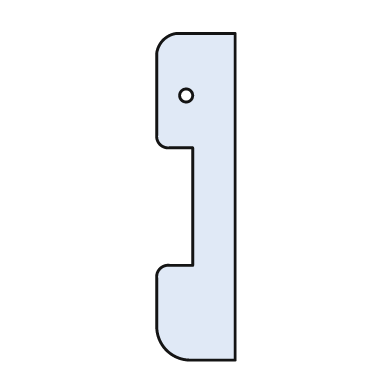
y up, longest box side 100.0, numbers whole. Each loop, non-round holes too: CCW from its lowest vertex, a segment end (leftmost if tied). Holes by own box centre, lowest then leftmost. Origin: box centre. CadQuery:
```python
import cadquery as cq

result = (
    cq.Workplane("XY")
    .moveTo(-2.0, -50.0)
    .lineTo(12.0, -50.0)
    .lineTo(12.0, 50.0)
    .lineTo(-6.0, 50.0)
    .threePointArc((-10.0, 48.0), (-12.0, 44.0))
    .lineTo(-12.0, 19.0)
    .threePointArc((-11.0, 16.0), (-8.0, 15.0))
    .lineTo(-1.0, 15.0)
    .lineTo(-1.0, -21.0)
    .lineTo(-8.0, -21.0)
    .threePointArc((-11.0, -22.0), (-12.0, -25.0))
    .lineTo(-12.0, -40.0)
    .threePointArc((-9.0, -47.0), (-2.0, -50.0))
    .close()
    .moveTo(-3.0, 31.0)
    .circle(2.0)
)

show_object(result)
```